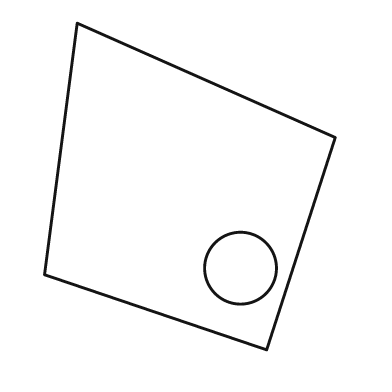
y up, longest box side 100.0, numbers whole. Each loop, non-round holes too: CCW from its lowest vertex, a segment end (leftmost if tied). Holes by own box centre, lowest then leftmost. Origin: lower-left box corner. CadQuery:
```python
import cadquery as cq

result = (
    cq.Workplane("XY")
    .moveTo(68.0, 0.0)
    .lineTo(89.0, 65.0)
    .lineTo(10.0, 100.0)
    .lineTo(0.0, 23.0)
    .close()
    .moveTo(60.0, 25.0)
    .circle(11.0)
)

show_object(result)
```